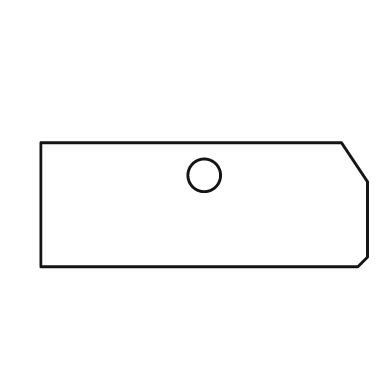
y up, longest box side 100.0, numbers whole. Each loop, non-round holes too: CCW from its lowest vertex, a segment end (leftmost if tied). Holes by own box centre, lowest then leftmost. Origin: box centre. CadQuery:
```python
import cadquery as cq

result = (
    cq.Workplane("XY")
    .moveTo(-50.0, -19.0)
    .lineTo(47.0, -19.0)
    .lineTo(50.0, -16.0)
    .lineTo(50.0, 7.0)
    .lineTo(42.0, 19.0)
    .lineTo(-50.0, 19.0)
    .close()
    .moveTo(0.0, 9.0)
    .circle(5.0)
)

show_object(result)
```